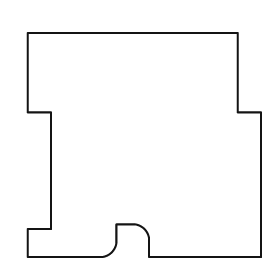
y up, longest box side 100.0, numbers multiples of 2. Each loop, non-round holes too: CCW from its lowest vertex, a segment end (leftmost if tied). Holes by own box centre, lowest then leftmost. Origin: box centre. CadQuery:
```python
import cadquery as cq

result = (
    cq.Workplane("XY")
    .moveTo(-50.0, -48.0)
    .lineTo(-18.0, -48.0)
    .threePointArc((-14.0, -46.0), (-12.0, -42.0))
    .lineTo(-12.0, -34.0)
    .lineTo(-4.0, -34.0)
    .threePointArc((0.0, -36.0), (2.0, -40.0))
    .lineTo(2.0, -48.0)
    .lineTo(50.0, -48.0)
    .lineTo(50.0, 14.0)
    .lineTo(40.0, 14.0)
    .lineTo(40.0, 48.0)
    .lineTo(-50.0, 48.0)
    .lineTo(-50.0, 14.0)
    .lineTo(-40.0, 14.0)
    .lineTo(-40.0, -36.0)
    .lineTo(-50.0, -36.0)
    .close()
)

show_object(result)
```